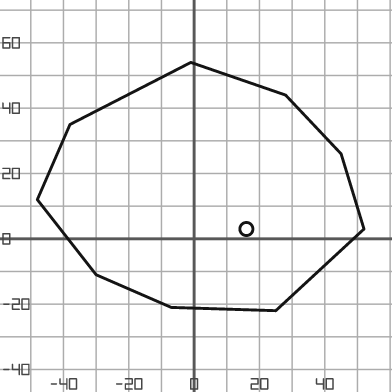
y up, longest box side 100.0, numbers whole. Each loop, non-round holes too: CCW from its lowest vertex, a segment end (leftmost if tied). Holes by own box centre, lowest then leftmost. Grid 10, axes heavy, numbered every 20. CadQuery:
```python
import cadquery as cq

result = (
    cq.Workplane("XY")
    .moveTo(25.0, -22.0)
    .lineTo(52.0, 3.0)
    .lineTo(45.0, 26.0)
    .lineTo(28.0, 44.0)
    .lineTo(-1.0, 54.0)
    .lineTo(-38.0, 35.0)
    .lineTo(-48.0, 12.0)
    .lineTo(-30.0, -11.0)
    .lineTo(-7.0, -21.0)
    .close()
    .moveTo(16.0, 3.0)
    .circle(2.0)
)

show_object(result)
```